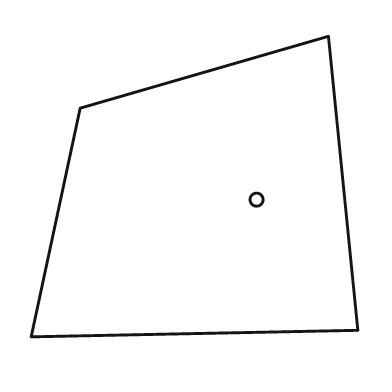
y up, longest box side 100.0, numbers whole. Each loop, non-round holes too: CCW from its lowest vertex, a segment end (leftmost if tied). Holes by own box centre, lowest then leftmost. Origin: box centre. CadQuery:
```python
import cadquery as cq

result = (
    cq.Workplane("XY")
    .moveTo(-50.0, -46.0)
    .lineTo(50.0, -44.0)
    .lineTo(41.0, 46.0)
    .lineTo(-35.0, 24.0)
    .close()
    .moveTo(19.0, -4.0)
    .circle(2.0)
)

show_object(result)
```